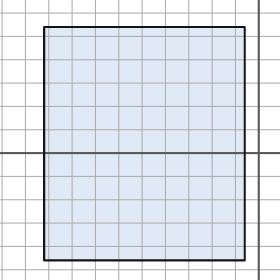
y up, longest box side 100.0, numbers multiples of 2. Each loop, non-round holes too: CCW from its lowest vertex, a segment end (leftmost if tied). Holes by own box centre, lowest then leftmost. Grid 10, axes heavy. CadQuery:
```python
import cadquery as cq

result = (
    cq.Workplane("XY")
    .moveTo(-92.0, -46.0)
    .lineTo(-6.0, -46.0)
    .lineTo(-6.0, 54.0)
    .lineTo(-92.0, 54.0)
    .close()
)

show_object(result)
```